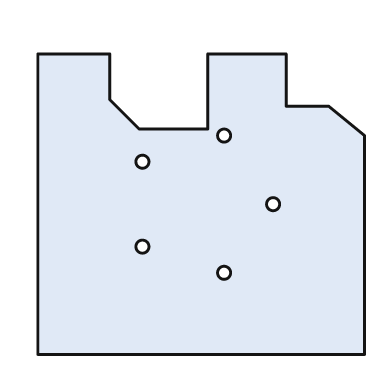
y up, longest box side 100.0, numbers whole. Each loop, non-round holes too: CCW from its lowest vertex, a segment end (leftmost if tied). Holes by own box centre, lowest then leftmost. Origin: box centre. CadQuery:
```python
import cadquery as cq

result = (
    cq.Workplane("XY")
    .moveTo(-50.0, -46.0)
    .lineTo(50.0, -46.0)
    .lineTo(50.0, 21.0)
    .lineTo(39.0, 30.0)
    .lineTo(26.0, 30.0)
    .lineTo(26.0, 46.0)
    .lineTo(2.0, 46.0)
    .lineTo(2.0, 23.0)
    .lineTo(-19.0, 23.0)
    .lineTo(-28.0, 32.0)
    .lineTo(-28.0, 46.0)
    .lineTo(-50.0, 46.0)
    .close()
    .moveTo(7.0, -21.0)
    .circle(2.0)
    .moveTo(-18.0, -13.0)
    .circle(2.0)
    .moveTo(22.0, 0.0)
    .circle(2.0)
    .moveTo(-18.0, 13.0)
    .circle(2.0)
    .moveTo(7.0, 21.0)
    .circle(2.0)
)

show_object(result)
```